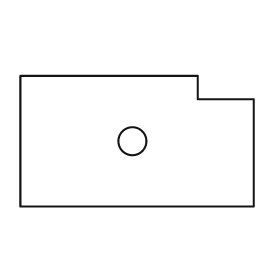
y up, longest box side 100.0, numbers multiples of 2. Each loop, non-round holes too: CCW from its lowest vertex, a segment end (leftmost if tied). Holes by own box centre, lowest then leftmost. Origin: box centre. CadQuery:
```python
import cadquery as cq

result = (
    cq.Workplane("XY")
    .moveTo(-50.0, -28.0)
    .lineTo(50.0, -28.0)
    .lineTo(50.0, 18.0)
    .lineTo(26.0, 18.0)
    .lineTo(26.0, 28.0)
    .lineTo(-50.0, 28.0)
    .close()
    .moveTo(-2.0, 0.0)
    .circle(6.0)
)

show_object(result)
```